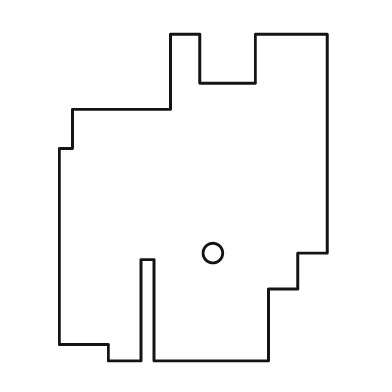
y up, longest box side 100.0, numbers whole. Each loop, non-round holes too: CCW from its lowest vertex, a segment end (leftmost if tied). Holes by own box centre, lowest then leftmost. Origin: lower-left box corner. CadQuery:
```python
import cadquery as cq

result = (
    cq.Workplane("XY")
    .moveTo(15.0, 0.0)
    .lineTo(25.0, 0.0)
    .lineTo(25.0, 31.0)
    .lineTo(29.0, 31.0)
    .lineTo(29.0, 0.0)
    .lineTo(64.0, 0.0)
    .lineTo(64.0, 22.0)
    .lineTo(73.0, 22.0)
    .lineTo(73.0, 33.0)
    .lineTo(82.0, 33.0)
    .lineTo(82.0, 100.0)
    .lineTo(60.0, 100.0)
    .lineTo(60.0, 85.0)
    .lineTo(43.0, 85.0)
    .lineTo(43.0, 100.0)
    .lineTo(34.0, 100.0)
    .lineTo(34.0, 77.0)
    .lineTo(4.0, 77.0)
    .lineTo(4.0, 65.0)
    .lineTo(0.0, 65.0)
    .lineTo(0.0, 5.0)
    .lineTo(15.0, 5.0)
    .close()
    .moveTo(47.0, 33.0)
    .circle(3.0)
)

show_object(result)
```